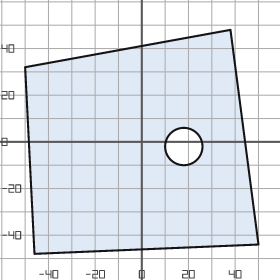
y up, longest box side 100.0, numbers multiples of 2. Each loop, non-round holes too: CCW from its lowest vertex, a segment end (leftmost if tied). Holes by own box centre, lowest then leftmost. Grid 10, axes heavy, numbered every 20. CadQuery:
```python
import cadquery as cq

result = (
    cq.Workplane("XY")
    .moveTo(-46.0, -48.0)
    .lineTo(50.0, -44.0)
    .lineTo(38.0, 48.0)
    .lineTo(-50.0, 32.0)
    .close()
    .moveTo(18.0, -2.0)
    .circle(8.0)
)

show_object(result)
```